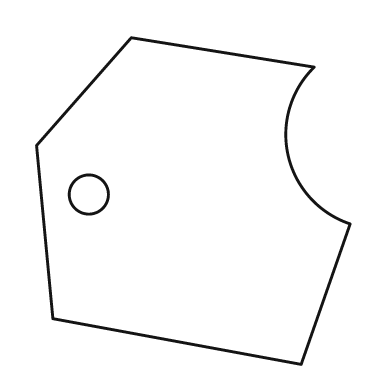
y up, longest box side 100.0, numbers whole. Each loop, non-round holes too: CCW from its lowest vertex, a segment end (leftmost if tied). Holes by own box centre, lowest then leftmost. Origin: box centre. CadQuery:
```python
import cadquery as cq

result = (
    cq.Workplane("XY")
    .moveTo(33.0, -50.0)
    .lineTo(48.0, -7.0)
    .threePointArc((29.0, 14.0), (37.0, 41.0))
    .lineTo(-19.0, 50.0)
    .lineTo(-48.0, 17.0)
    .lineTo(-43.0, -36.0)
    .close()
    .moveTo(-32.0, 2.0)
    .circle(6.0)
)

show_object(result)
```